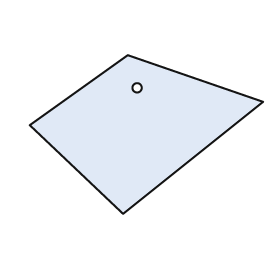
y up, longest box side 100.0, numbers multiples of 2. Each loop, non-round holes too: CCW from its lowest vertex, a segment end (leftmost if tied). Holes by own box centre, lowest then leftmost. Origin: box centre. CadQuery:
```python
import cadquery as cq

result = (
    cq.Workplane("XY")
    .moveTo(-10.0, -34.0)
    .lineTo(50.0, 14.0)
    .lineTo(-8.0, 34.0)
    .lineTo(-50.0, 4.0)
    .close()
    .moveTo(-4.0, 20.0)
    .circle(2.0)
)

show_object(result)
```